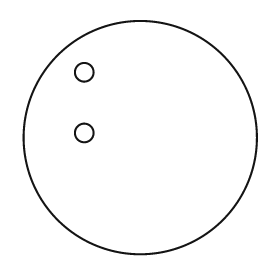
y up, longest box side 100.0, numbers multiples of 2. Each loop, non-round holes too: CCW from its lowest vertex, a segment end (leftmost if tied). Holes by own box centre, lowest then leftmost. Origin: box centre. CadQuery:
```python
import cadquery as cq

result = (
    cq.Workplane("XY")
    .moveTo(0.0, 0.0)
    .circle(50.0)
    .moveTo(-24.0, 2.0)
    .circle(4.0)
    .moveTo(-24.0, 28.0)
    .circle(4.0)
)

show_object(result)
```